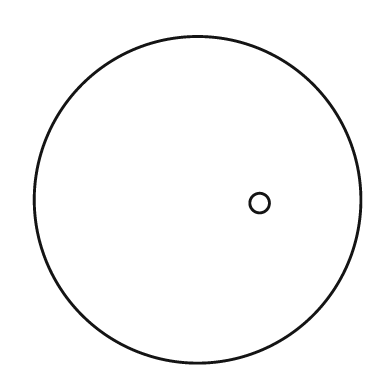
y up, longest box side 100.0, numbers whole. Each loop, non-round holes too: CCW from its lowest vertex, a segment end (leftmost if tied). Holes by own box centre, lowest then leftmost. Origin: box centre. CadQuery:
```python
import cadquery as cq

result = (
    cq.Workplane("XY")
    .moveTo(0.0, 0.0)
    .circle(50.0)
    .moveTo(19.0, -1.0)
    .circle(3.0)
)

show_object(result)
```